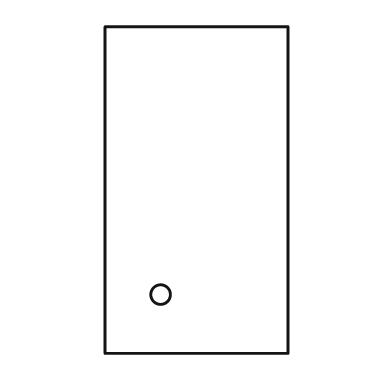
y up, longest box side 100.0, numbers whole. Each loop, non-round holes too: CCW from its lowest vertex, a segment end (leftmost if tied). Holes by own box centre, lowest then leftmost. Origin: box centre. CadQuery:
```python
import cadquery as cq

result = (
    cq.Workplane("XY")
    .moveTo(-28.0, -50.0)
    .lineTo(28.0, -50.0)
    .lineTo(28.0, 50.0)
    .lineTo(-28.0, 50.0)
    .close()
    .moveTo(-11.0, -32.0)
    .circle(3.0)
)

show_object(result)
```